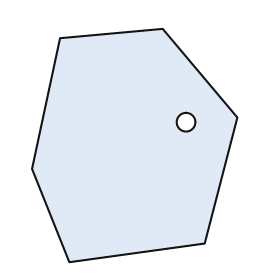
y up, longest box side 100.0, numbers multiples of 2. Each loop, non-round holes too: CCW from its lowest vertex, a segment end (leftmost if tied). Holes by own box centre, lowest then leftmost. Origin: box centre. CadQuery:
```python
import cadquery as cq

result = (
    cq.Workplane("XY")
    .moveTo(-28.0, -50.0)
    .lineTo(30.0, -42.0)
    .lineTo(44.0, 12.0)
    .lineTo(12.0, 50.0)
    .lineTo(-32.0, 46.0)
    .lineTo(-44.0, -10.0)
    .close()
    .moveTo(22.0, 10.0)
    .circle(4.0)
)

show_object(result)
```